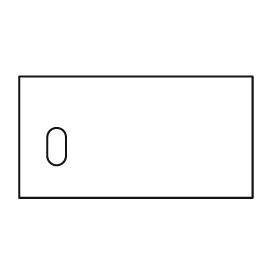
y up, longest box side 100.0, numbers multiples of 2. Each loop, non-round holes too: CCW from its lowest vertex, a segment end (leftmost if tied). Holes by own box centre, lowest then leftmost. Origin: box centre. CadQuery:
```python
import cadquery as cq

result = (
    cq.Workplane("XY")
    .moveTo(-50.0, -26.0)
    .lineTo(50.0, -26.0)
    .lineTo(50.0, 26.0)
    .lineTo(-50.0, 26.0)
    .close()
    .moveTo(-38.0, -8.0)
    .threePointArc((-34.0, -12.0), (-30.0, -8.0))
    .lineTo(-30.0, 0.0)
    .threePointArc((-34.0, 4.0), (-38.0, 0.0))
    .close()
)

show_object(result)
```